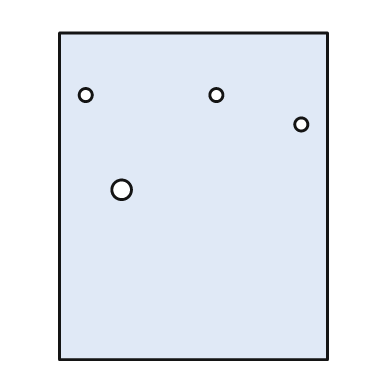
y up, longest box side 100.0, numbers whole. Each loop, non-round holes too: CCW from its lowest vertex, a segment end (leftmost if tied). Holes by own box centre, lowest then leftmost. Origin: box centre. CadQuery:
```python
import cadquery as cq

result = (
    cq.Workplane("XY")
    .moveTo(-41.0, -50.0)
    .lineTo(41.0, -50.0)
    .lineTo(41.0, 50.0)
    .lineTo(-41.0, 50.0)
    .close()
    .moveTo(-22.0, 2.0)
    .circle(3.0)
    .moveTo(33.0, 22.0)
    .circle(2.0)
    .moveTo(-33.0, 31.0)
    .circle(2.0)
    .moveTo(7.0, 31.0)
    .circle(2.0)
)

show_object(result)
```